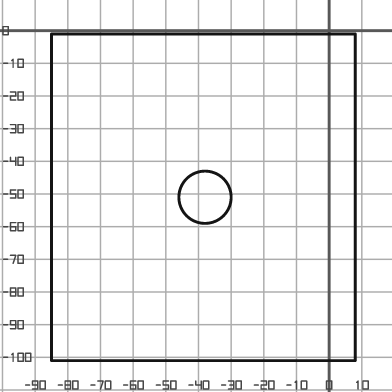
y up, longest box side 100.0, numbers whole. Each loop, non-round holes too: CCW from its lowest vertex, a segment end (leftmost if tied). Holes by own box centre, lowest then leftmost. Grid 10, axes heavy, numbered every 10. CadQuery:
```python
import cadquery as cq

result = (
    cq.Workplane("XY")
    .moveTo(-85.0, -101.0)
    .lineTo(8.0, -101.0)
    .lineTo(8.0, -1.0)
    .lineTo(-85.0, -1.0)
    .close()
    .moveTo(-38.0, -51.0)
    .circle(8.0)
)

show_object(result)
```